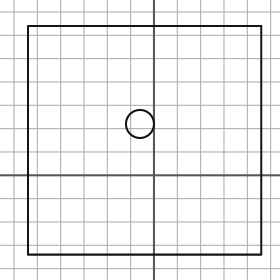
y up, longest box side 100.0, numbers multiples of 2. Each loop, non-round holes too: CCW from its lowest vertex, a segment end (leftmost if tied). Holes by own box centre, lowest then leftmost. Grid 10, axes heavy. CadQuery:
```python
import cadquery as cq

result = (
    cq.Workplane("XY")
    .moveTo(-54.0, -34.0)
    .lineTo(46.0, -34.0)
    .lineTo(46.0, 64.0)
    .lineTo(-54.0, 64.0)
    .close()
    .moveTo(-6.0, 22.0)
    .circle(6.0)
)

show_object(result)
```